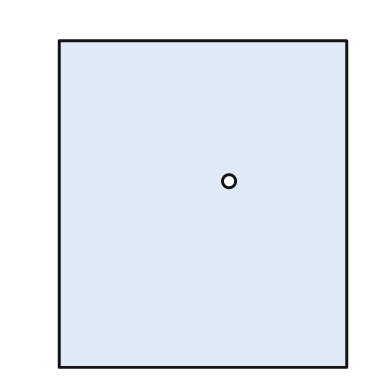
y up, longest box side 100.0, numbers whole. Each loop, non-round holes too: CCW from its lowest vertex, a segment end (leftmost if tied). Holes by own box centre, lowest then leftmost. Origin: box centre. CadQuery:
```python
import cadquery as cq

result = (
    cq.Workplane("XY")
    .moveTo(-44.0, -50.0)
    .lineTo(44.0, -50.0)
    .lineTo(44.0, 50.0)
    .lineTo(-44.0, 50.0)
    .close()
    .moveTo(8.0, 7.0)
    .circle(2.0)
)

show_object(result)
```